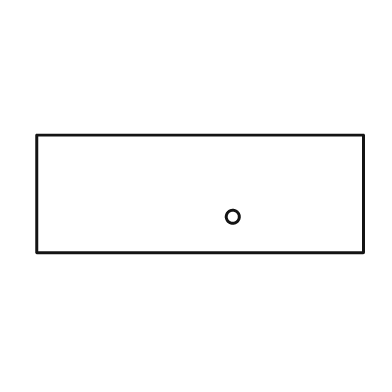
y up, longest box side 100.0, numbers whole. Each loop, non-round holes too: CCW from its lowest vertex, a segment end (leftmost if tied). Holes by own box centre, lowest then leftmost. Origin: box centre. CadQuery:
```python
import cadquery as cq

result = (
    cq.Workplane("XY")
    .moveTo(-50.0, -18.0)
    .lineTo(50.0, -18.0)
    .lineTo(50.0, 18.0)
    .lineTo(-50.0, 18.0)
    .close()
    .moveTo(10.0, -7.0)
    .circle(2.0)
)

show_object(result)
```